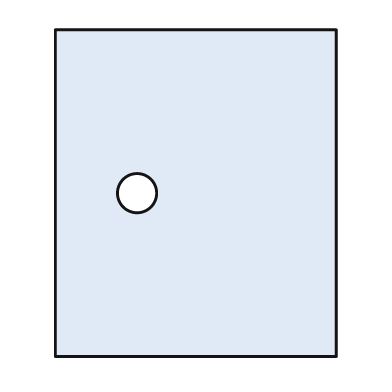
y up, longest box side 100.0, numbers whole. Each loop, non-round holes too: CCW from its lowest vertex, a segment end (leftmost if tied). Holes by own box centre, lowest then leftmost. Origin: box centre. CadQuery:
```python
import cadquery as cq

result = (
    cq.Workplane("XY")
    .moveTo(-43.0, -50.0)
    .lineTo(43.0, -50.0)
    .lineTo(43.0, 50.0)
    .lineTo(-43.0, 50.0)
    .close()
    .moveTo(-18.0, 0.0)
    .circle(6.0)
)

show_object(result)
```